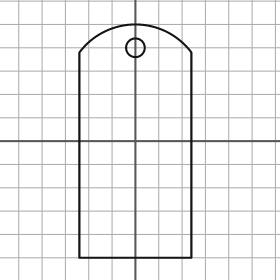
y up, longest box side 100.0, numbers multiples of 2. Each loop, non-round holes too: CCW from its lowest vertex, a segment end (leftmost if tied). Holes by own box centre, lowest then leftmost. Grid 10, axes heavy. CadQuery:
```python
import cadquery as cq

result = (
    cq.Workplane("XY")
    .moveTo(-24.0, -50.0)
    .lineTo(24.0, -50.0)
    .lineTo(24.0, 38.0)
    .threePointArc((0.0, 50.0), (-24.0, 38.0))
    .close()
    .moveTo(0.0, 40.0)
    .circle(4.0)
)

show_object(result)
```